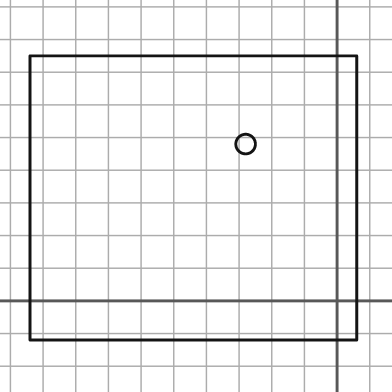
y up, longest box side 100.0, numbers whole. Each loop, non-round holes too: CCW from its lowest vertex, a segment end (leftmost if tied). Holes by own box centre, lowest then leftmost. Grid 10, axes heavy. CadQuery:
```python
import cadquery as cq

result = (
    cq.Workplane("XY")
    .moveTo(-94.0, -12.0)
    .lineTo(6.0, -12.0)
    .lineTo(6.0, 75.0)
    .lineTo(-94.0, 75.0)
    .close()
    .moveTo(-28.0, 48.0)
    .circle(3.0)
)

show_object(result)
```